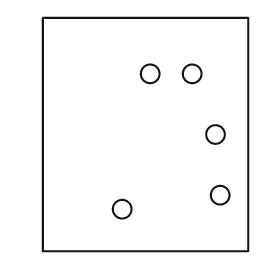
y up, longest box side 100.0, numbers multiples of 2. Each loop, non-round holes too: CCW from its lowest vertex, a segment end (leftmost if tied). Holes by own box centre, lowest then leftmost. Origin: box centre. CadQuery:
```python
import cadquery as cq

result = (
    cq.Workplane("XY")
    .moveTo(-44.0, -50.0)
    .lineTo(44.0, -50.0)
    .lineTo(44.0, 50.0)
    .lineTo(-44.0, 50.0)
    .close()
    .moveTo(-10.0, -32.0)
    .circle(4.0)
    .moveTo(32.0, -26.0)
    .circle(4.0)
    .moveTo(30.0, 0.0)
    .circle(4.0)
    .moveTo(2.0, 26.0)
    .circle(4.0)
    .moveTo(20.0, 26.0)
    .circle(4.0)
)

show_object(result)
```